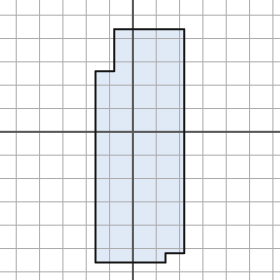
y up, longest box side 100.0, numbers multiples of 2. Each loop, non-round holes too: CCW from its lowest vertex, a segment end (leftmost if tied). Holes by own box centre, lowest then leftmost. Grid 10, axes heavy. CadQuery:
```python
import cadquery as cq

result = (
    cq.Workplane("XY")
    .moveTo(-16.0, -56.0)
    .lineTo(14.0, -56.0)
    .lineTo(14.0, -52.0)
    .lineTo(22.0, -52.0)
    .lineTo(22.0, 44.0)
    .lineTo(-8.0, 44.0)
    .lineTo(-8.0, 26.0)
    .lineTo(-16.0, 26.0)
    .close()
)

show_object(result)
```